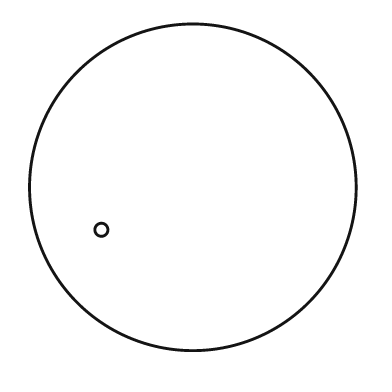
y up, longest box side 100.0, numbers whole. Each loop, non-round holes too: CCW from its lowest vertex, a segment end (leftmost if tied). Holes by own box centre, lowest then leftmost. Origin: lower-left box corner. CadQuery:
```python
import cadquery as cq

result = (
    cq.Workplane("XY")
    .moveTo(50.0, 50.0)
    .circle(50.0)
    .moveTo(22.0, 37.0)
    .circle(2.0)
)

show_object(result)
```